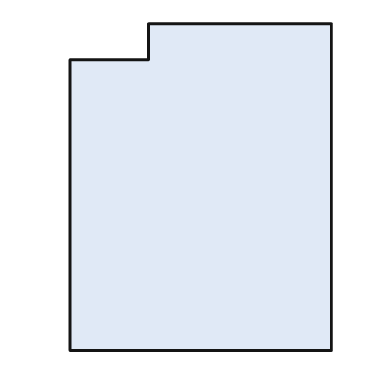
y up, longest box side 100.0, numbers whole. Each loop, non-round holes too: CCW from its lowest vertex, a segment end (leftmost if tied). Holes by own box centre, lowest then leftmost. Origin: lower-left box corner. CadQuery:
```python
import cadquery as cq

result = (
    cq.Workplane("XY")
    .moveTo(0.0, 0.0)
    .lineTo(80.0, 0.0)
    .lineTo(80.0, 100.0)
    .lineTo(24.0, 100.0)
    .lineTo(24.0, 89.0)
    .lineTo(0.0, 89.0)
    .close()
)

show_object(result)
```